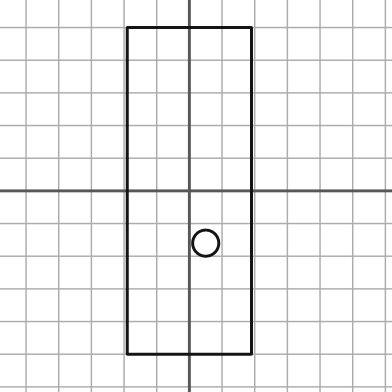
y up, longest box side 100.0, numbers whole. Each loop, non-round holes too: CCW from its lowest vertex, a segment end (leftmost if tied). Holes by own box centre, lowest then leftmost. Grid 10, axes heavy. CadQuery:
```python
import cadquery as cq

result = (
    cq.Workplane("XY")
    .moveTo(-19.0, -50.0)
    .lineTo(19.0, -50.0)
    .lineTo(19.0, 50.0)
    .lineTo(-19.0, 50.0)
    .close()
    .moveTo(5.0, -16.0)
    .circle(4.0)
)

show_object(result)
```